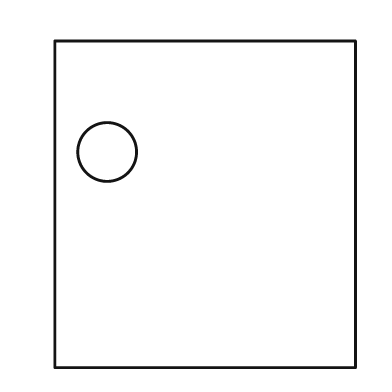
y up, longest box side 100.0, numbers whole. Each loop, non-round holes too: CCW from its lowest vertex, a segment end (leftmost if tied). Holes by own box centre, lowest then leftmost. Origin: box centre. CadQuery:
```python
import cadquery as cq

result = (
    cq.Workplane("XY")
    .moveTo(-46.0, -50.0)
    .lineTo(46.0, -50.0)
    .lineTo(46.0, 50.0)
    .lineTo(-46.0, 50.0)
    .close()
    .moveTo(-30.0, 16.0)
    .circle(9.0)
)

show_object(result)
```